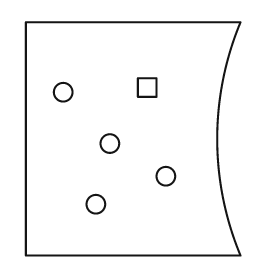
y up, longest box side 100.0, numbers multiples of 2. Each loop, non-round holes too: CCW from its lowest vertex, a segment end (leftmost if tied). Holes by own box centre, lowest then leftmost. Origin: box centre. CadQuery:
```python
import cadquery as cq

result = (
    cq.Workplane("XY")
    .moveTo(-46.0, -50.0)
    .lineTo(46.0, -50.0)
    .threePointArc((36.0, 0.0), (46.0, 50.0))
    .lineTo(-46.0, 50.0)
    .close()
    .moveTo(-16.0, -28.0)
    .circle(4.0)
    .moveTo(14.0, -16.0)
    .circle(4.0)
    .moveTo(-10.0, -2.0)
    .circle(4.0)
    .moveTo(-30.0, 20.0)
    .circle(4.0)
    .moveTo(2.0, 18.0)
    .lineTo(10.0, 18.0)
    .lineTo(10.0, 26.0)
    .lineTo(2.0, 26.0)
    .close()
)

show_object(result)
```